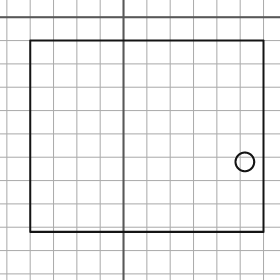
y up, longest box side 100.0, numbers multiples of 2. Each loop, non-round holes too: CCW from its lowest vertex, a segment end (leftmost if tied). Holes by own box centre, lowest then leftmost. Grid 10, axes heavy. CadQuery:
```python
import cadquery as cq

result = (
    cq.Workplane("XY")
    .moveTo(-40.0, -92.0)
    .lineTo(60.0, -92.0)
    .lineTo(60.0, -10.0)
    .lineTo(-40.0, -10.0)
    .close()
    .moveTo(52.0, -62.0)
    .circle(4.0)
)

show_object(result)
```